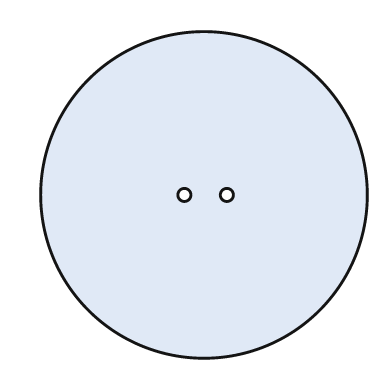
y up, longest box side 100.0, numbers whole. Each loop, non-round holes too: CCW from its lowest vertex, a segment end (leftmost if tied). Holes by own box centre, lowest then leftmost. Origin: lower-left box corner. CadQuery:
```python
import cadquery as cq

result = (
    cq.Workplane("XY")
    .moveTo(50.0, 50.0)
    .circle(50.0)
    .moveTo(44.0, 50.0)
    .circle(2.0)
    .moveTo(57.0, 50.0)
    .circle(2.0)
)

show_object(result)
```